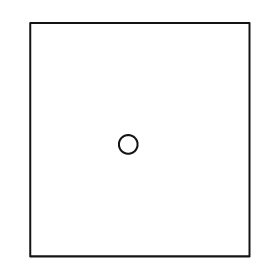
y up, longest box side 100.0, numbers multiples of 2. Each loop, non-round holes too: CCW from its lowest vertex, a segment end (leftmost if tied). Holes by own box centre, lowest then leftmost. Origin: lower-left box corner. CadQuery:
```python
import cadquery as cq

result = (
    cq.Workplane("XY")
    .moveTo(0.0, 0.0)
    .lineTo(94.0, 0.0)
    .lineTo(94.0, 100.0)
    .lineTo(0.0, 100.0)
    .close()
    .moveTo(42.0, 48.0)
    .circle(4.0)
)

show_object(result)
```